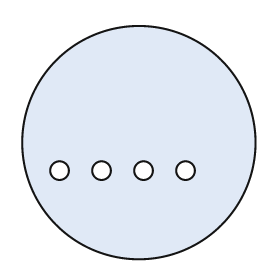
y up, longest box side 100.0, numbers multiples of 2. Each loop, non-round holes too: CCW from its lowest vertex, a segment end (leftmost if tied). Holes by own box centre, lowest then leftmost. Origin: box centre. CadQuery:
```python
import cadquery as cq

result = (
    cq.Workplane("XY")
    .moveTo(0.0, 0.0)
    .circle(50.0)
    .moveTo(-34.0, -12.0)
    .circle(4.0)
    .moveTo(-16.0, -12.0)
    .circle(4.0)
    .moveTo(2.0, -12.0)
    .circle(4.0)
    .moveTo(20.0, -12.0)
    .circle(4.0)
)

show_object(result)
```